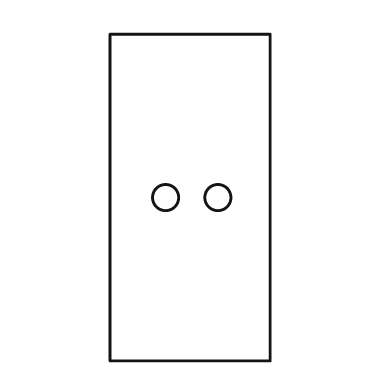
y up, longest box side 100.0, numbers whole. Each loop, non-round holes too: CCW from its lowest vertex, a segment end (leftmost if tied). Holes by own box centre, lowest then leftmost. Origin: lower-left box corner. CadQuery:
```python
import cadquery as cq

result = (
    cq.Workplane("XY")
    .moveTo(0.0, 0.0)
    .lineTo(49.0, 0.0)
    .lineTo(49.0, 100.0)
    .lineTo(0.0, 100.0)
    .close()
    .moveTo(17.0, 50.0)
    .circle(4.0)
    .moveTo(33.0, 50.0)
    .circle(4.0)
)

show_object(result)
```